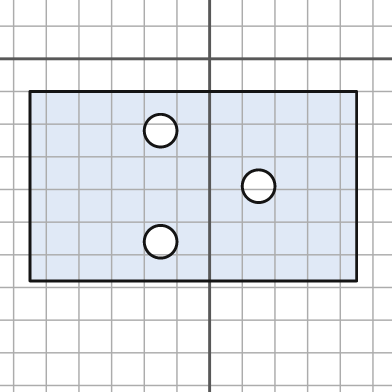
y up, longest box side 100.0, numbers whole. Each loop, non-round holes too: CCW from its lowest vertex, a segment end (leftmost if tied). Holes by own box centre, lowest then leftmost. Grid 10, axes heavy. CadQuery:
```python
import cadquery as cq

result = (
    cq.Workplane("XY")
    .moveTo(-55.0, -68.0)
    .lineTo(45.0, -68.0)
    .lineTo(45.0, -10.0)
    .lineTo(-55.0, -10.0)
    .close()
    .moveTo(-15.0, -56.0)
    .circle(5.0)
    .moveTo(15.0, -39.0)
    .circle(5.0)
    .moveTo(-15.0, -22.0)
    .circle(5.0)
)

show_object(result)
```